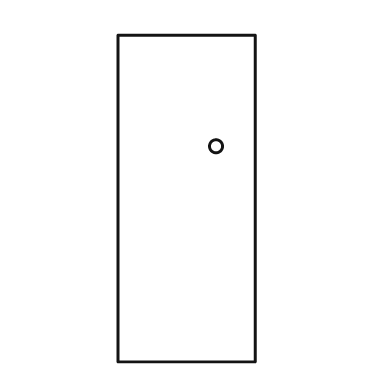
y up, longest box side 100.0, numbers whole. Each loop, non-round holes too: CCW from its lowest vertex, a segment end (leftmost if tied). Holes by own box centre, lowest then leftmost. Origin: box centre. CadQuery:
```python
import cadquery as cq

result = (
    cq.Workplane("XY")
    .moveTo(-21.0, -50.0)
    .lineTo(21.0, -50.0)
    .lineTo(21.0, 50.0)
    .lineTo(-21.0, 50.0)
    .close()
    .moveTo(9.0, 16.0)
    .circle(2.0)
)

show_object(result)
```